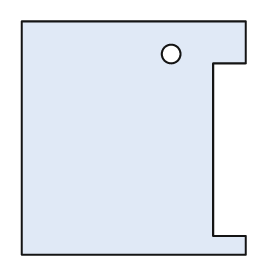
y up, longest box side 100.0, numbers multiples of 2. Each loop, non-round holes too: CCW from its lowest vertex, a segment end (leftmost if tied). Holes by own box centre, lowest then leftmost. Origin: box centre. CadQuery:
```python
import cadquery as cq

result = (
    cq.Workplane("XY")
    .moveTo(-48.0, -50.0)
    .lineTo(48.0, -50.0)
    .lineTo(48.0, -42.0)
    .lineTo(34.0, -42.0)
    .lineTo(34.0, 32.0)
    .lineTo(48.0, 32.0)
    .lineTo(48.0, 50.0)
    .lineTo(-48.0, 50.0)
    .close()
    .moveTo(16.0, 36.0)
    .circle(4.0)
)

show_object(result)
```